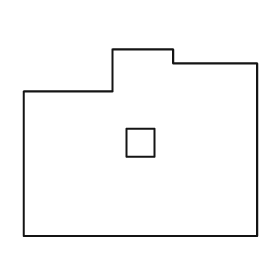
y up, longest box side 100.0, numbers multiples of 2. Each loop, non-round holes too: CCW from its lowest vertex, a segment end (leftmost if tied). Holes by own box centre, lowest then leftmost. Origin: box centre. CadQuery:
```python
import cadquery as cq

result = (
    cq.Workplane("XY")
    .moveTo(-50.0, -40.0)
    .lineTo(50.0, -40.0)
    .lineTo(50.0, 34.0)
    .lineTo(14.0, 34.0)
    .lineTo(14.0, 40.0)
    .lineTo(-12.0, 40.0)
    .lineTo(-12.0, 22.0)
    .lineTo(-50.0, 22.0)
    .close()
    .moveTo(-6.0, -6.0)
    .lineTo(6.0, -6.0)
    .lineTo(6.0, 6.0)
    .lineTo(-6.0, 6.0)
    .close()
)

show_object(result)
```